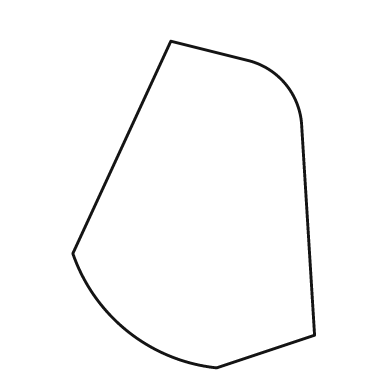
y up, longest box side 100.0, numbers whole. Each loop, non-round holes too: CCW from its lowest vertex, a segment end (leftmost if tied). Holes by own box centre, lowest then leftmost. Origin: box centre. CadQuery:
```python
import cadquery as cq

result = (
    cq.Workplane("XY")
    .moveTo(7.0, -50.0)
    .lineTo(37.0, -40.0)
    .lineTo(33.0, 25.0)
    .threePointArc((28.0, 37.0), (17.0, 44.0))
    .lineTo(-7.0, 50.0)
    .lineTo(-37.0, -15.0)
    .threePointArc((-20.0, -39.0), (7.0, -50.0))
    .close()
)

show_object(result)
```